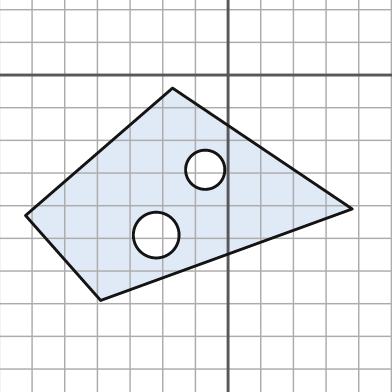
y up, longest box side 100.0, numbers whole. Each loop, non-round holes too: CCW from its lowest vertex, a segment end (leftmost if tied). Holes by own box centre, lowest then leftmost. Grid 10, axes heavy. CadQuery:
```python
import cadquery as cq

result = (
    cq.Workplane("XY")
    .moveTo(-39.0, -69.0)
    .lineTo(38.0, -41.0)
    .lineTo(-17.0, -4.0)
    .lineTo(-62.0, -43.0)
    .close()
    .moveTo(-22.0, -49.0)
    .circle(7.0)
    .moveTo(-7.0, -29.0)
    .circle(6.0)
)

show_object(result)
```